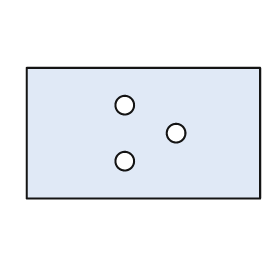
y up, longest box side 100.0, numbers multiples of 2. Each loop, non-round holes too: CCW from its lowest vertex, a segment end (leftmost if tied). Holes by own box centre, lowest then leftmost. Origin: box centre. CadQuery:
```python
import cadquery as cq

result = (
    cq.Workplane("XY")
    .moveTo(-50.0, -28.0)
    .lineTo(50.0, -28.0)
    .lineTo(50.0, 28.0)
    .lineTo(-50.0, 28.0)
    .close()
    .moveTo(-8.0, -12.0)
    .circle(4.0)
    .moveTo(14.0, 0.0)
    .circle(4.0)
    .moveTo(-8.0, 12.0)
    .circle(4.0)
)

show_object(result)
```